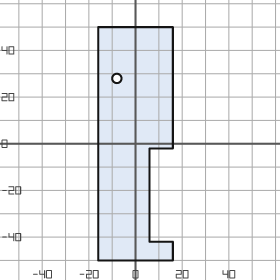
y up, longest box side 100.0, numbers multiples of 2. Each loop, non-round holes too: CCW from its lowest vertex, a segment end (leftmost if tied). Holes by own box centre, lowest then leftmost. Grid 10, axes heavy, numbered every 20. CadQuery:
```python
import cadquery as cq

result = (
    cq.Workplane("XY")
    .moveTo(-16.0, -50.0)
    .lineTo(16.0, -50.0)
    .lineTo(16.0, -42.0)
    .lineTo(6.0, -42.0)
    .lineTo(6.0, -2.0)
    .lineTo(16.0, -2.0)
    .lineTo(16.0, 50.0)
    .lineTo(-16.0, 50.0)
    .close()
    .moveTo(-8.0, 28.0)
    .circle(2.0)
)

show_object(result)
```